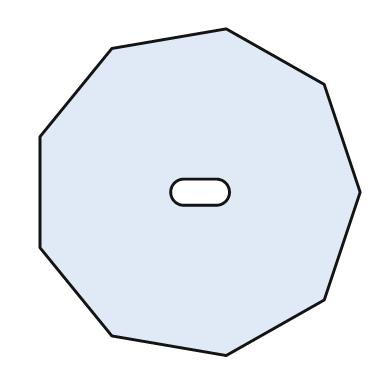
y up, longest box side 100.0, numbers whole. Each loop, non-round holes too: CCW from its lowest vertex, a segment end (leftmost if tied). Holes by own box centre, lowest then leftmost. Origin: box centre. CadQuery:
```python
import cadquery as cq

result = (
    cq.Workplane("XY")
    .moveTo(8.0, -50.0)
    .lineTo(38.0, -33.0)
    .lineTo(49.0, 0.0)
    .lineTo(38.0, 33.0)
    .lineTo(8.0, 50.0)
    .lineTo(-27.0, 44.0)
    .lineTo(-49.0, 17.0)
    .lineTo(-49.0, -17.0)
    .lineTo(-27.0, -44.0)
    .close()
    .moveTo(-5.0, -4.0)
    .lineTo(5.0, -4.0)
    .threePointArc((9.0, 0.0), (5.0, 4.0))
    .lineTo(-5.0, 4.0)
    .threePointArc((-9.0, 0.0), (-5.0, -4.0))
    .close()
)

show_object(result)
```